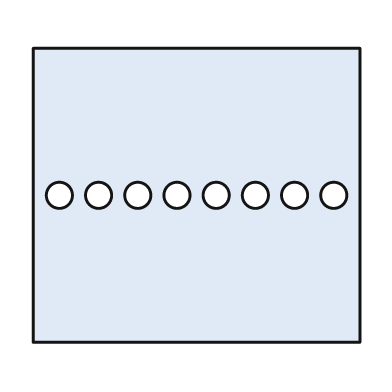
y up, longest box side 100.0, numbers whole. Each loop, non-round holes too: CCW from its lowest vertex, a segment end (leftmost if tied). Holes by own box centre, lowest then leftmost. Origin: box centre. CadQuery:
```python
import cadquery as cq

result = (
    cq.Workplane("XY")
    .moveTo(-50.0, -45.0)
    .lineTo(50.0, -45.0)
    .lineTo(50.0, 45.0)
    .lineTo(-50.0, 45.0)
    .close()
    .moveTo(-42.0, 0.0)
    .circle(4.0)
    .moveTo(-30.0, 0.0)
    .circle(4.0)
    .moveTo(-18.0, 0.0)
    .circle(4.0)
    .moveTo(-6.0, 0.0)
    .circle(4.0)
    .moveTo(6.0, 0.0)
    .circle(4.0)
    .moveTo(18.0, 0.0)
    .circle(4.0)
    .moveTo(30.0, 0.0)
    .circle(4.0)
    .moveTo(42.0, 0.0)
    .circle(4.0)
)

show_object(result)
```